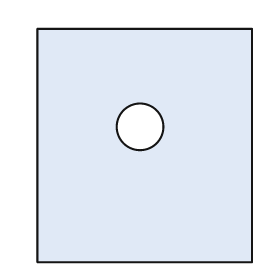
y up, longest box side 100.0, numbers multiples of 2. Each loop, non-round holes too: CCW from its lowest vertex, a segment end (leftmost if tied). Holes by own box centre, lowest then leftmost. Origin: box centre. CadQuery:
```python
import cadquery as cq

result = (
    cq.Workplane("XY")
    .moveTo(-46.0, -50.0)
    .lineTo(46.0, -50.0)
    .lineTo(46.0, 50.0)
    .lineTo(-46.0, 50.0)
    .close()
    .moveTo(-2.0, 8.0)
    .circle(10.0)
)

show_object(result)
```